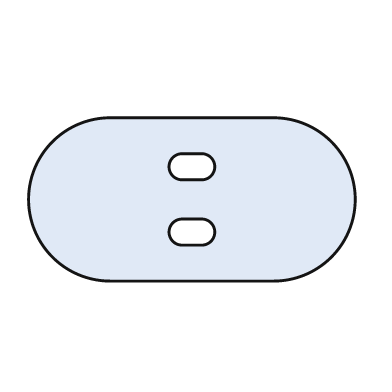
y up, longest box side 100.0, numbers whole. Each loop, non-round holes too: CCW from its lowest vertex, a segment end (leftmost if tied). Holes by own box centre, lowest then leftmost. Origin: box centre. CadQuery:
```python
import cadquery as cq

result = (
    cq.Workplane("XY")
    .moveTo(-25.0, -25.0)
    .lineTo(25.0, -25.0)
    .threePointArc((50.0, 0.0), (25.0, 25.0))
    .lineTo(-25.0, 25.0)
    .threePointArc((-50.0, 0.0), (-25.0, -25.0))
    .close()
    .moveTo(-3.0, -14.0)
    .lineTo(3.0, -14.0)
    .threePointArc((7.0, -10.0), (3.0, -6.0))
    .lineTo(-3.0, -6.0)
    .threePointArc((-7.0, -10.0), (-3.0, -14.0))
    .close()
    .moveTo(-3.0, 6.0)
    .lineTo(3.0, 6.0)
    .threePointArc((7.0, 10.0), (3.0, 14.0))
    .lineTo(-3.0, 14.0)
    .threePointArc((-7.0, 10.0), (-3.0, 6.0))
    .close()
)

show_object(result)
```